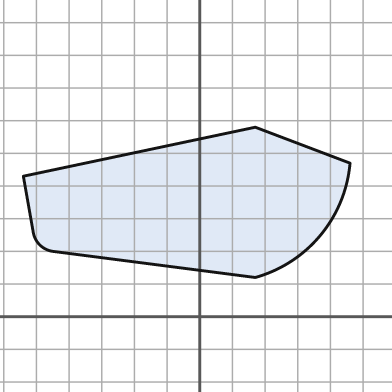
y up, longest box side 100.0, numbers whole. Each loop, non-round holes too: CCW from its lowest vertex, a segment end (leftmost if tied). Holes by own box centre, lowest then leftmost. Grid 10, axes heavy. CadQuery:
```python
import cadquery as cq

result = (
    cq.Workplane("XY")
    .moveTo(17.0, 12.0)
    .threePointArc((37.0, 25.0), (46.0, 47.0))
    .lineTo(17.0, 58.0)
    .lineTo(-54.0, 43.0)
    .lineTo(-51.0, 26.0)
    .threePointArc((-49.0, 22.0), (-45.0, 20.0))
    .close()
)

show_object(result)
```